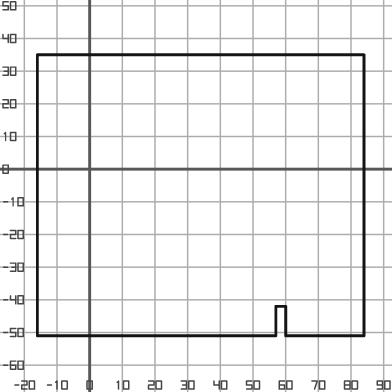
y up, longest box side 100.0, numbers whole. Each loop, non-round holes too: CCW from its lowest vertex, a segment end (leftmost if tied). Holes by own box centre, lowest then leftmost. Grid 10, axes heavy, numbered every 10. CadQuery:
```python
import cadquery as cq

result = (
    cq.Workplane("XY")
    .moveTo(-16.0, -51.0)
    .lineTo(57.0, -51.0)
    .lineTo(57.0, -42.0)
    .lineTo(60.0, -42.0)
    .lineTo(60.0, -51.0)
    .lineTo(84.0, -51.0)
    .lineTo(84.0, 35.0)
    .lineTo(-16.0, 35.0)
    .close()
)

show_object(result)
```